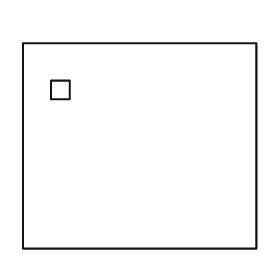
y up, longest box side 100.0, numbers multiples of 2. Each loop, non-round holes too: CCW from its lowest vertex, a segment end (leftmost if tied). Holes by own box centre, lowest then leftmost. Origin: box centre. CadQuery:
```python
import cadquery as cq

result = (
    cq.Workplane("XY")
    .moveTo(-50.0, -44.0)
    .lineTo(50.0, -44.0)
    .lineTo(50.0, 44.0)
    .lineTo(-50.0, 44.0)
    .close()
    .moveTo(-38.0, 20.0)
    .lineTo(-30.0, 20.0)
    .lineTo(-30.0, 28.0)
    .lineTo(-38.0, 28.0)
    .close()
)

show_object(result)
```